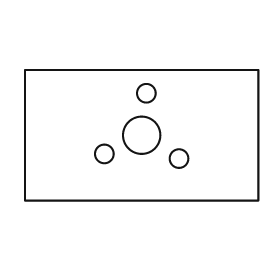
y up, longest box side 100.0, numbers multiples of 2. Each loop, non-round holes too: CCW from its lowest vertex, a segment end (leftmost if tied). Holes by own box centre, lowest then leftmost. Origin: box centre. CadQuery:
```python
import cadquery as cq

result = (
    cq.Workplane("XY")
    .moveTo(-50.0, -28.0)
    .lineTo(50.0, -28.0)
    .lineTo(50.0, 28.0)
    .lineTo(-50.0, 28.0)
    .close()
    .moveTo(16.0, -10.0)
    .circle(4.0)
    .moveTo(-16.0, -8.0)
    .circle(4.0)
    .moveTo(0.0, 0.0)
    .circle(8.0)
    .moveTo(2.0, 18.0)
    .circle(4.0)
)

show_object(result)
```